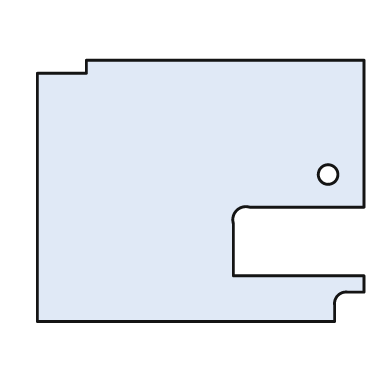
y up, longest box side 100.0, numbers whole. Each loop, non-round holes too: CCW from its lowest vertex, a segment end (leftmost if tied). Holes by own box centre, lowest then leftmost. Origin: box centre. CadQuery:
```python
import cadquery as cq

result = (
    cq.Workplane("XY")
    .moveTo(-50.0, -40.0)
    .lineTo(41.0, -40.0)
    .lineTo(41.0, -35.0)
    .threePointArc((42.0, -32.0), (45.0, -31.0))
    .lineTo(50.0, -31.0)
    .lineTo(50.0, -26.0)
    .lineTo(10.0, -26.0)
    .lineTo(10.0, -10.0)
    .threePointArc((11.0, -6.0), (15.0, -5.0))
    .lineTo(50.0, -5.0)
    .lineTo(50.0, 40.0)
    .lineTo(-35.0, 40.0)
    .lineTo(-35.0, 36.0)
    .lineTo(-50.0, 36.0)
    .close()
    .moveTo(39.0, 5.0)
    .circle(3.0)
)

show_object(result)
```